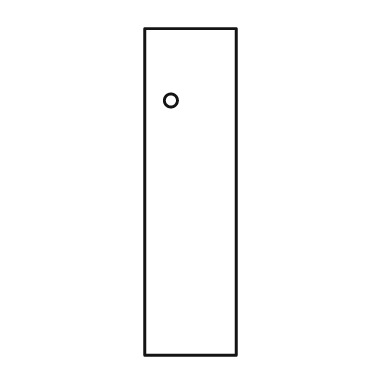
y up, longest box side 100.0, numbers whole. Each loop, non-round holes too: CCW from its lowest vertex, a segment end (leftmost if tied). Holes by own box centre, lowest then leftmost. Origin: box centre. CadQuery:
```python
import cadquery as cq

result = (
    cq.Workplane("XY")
    .moveTo(-14.0, -50.0)
    .lineTo(14.0, -50.0)
    .lineTo(14.0, 50.0)
    .lineTo(-14.0, 50.0)
    .close()
    .moveTo(-6.0, 28.0)
    .circle(2.0)
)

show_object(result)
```